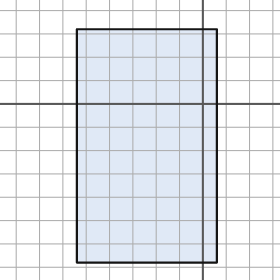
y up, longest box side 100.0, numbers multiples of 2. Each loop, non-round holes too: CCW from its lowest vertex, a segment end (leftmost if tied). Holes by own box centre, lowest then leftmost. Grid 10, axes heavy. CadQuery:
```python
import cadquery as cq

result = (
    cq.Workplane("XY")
    .moveTo(-54.0, -68.0)
    .lineTo(6.0, -68.0)
    .lineTo(6.0, 32.0)
    .lineTo(-54.0, 32.0)
    .close()
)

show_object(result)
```